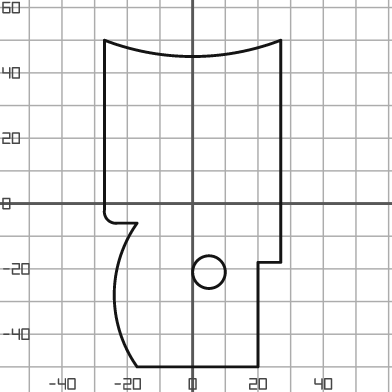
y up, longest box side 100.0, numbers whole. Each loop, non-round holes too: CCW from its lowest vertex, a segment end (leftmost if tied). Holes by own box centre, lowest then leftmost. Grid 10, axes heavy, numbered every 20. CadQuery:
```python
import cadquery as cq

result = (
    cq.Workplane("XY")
    .moveTo(-17.0, -50.0)
    .lineTo(20.0, -50.0)
    .lineTo(20.0, -18.0)
    .lineTo(27.0, -18.0)
    .lineTo(27.0, 50.0)
    .threePointArc((0.0, 45.0), (-27.0, 50.0))
    .lineTo(-27.0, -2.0)
    .threePointArc((-26.0, -5.0), (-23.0, -6.0))
    .lineTo(-17.0, -6.0)
    .threePointArc((-24.0, -28.0), (-17.0, -50.0))
    .close()
    .moveTo(5.0, -21.0)
    .circle(5.0)
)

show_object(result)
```